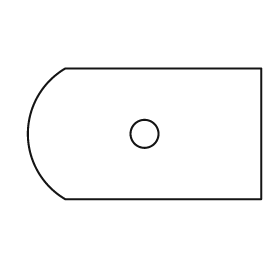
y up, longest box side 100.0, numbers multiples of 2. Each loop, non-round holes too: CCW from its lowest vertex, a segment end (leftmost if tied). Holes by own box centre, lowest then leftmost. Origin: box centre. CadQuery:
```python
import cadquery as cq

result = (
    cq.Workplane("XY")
    .moveTo(-34.0, -28.0)
    .lineTo(50.0, -28.0)
    .lineTo(50.0, 28.0)
    .lineTo(-34.0, 28.0)
    .threePointArc((-50.0, 0.0), (-34.0, -28.0))
    .close()
    .moveTo(0.0, 0.0)
    .circle(6.0)
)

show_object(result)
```